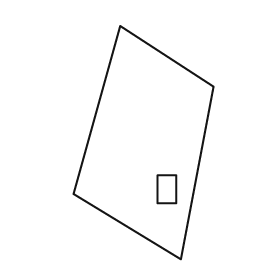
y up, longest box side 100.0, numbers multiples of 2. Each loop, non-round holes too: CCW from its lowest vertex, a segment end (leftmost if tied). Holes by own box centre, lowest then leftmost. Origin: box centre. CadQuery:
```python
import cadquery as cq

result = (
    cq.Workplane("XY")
    .moveTo(16.0, -50.0)
    .lineTo(30.0, 24.0)
    .lineTo(-10.0, 50.0)
    .lineTo(-30.0, -22.0)
    .close()
    .moveTo(6.0, -26.0)
    .lineTo(14.0, -26.0)
    .lineTo(14.0, -14.0)
    .lineTo(6.0, -14.0)
    .close()
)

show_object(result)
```